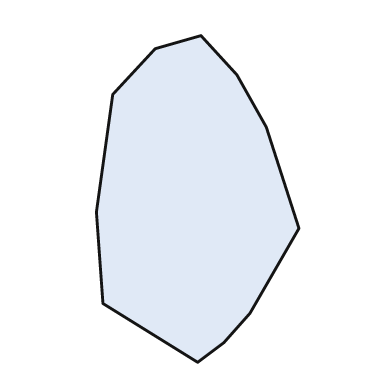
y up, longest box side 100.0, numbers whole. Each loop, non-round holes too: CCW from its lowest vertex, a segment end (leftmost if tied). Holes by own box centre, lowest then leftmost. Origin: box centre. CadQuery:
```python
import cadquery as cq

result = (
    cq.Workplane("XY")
    .moveTo(0.0, -50.0)
    .lineTo(8.0, -44.0)
    .lineTo(16.0, -35.0)
    .lineTo(31.0, -9.0)
    .lineTo(21.0, 22.0)
    .lineTo(12.0, 38.0)
    .lineTo(1.0, 50.0)
    .lineTo(-13.0, 46.0)
    .lineTo(-26.0, 32.0)
    .lineTo(-31.0, -4.0)
    .lineTo(-29.0, -32.0)
    .close()
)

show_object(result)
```